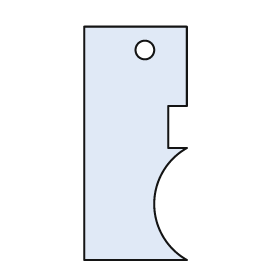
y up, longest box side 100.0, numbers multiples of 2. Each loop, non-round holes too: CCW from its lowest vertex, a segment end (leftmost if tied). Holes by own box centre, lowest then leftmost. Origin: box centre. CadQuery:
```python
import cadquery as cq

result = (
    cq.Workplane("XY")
    .moveTo(-22.0, -50.0)
    .lineTo(22.0, -50.0)
    .threePointArc((8.0, -26.0), (22.0, -2.0))
    .lineTo(14.0, -2.0)
    .lineTo(14.0, 16.0)
    .lineTo(22.0, 16.0)
    .lineTo(22.0, 50.0)
    .lineTo(-22.0, 50.0)
    .close()
    .moveTo(4.0, 40.0)
    .circle(4.0)
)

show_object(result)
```